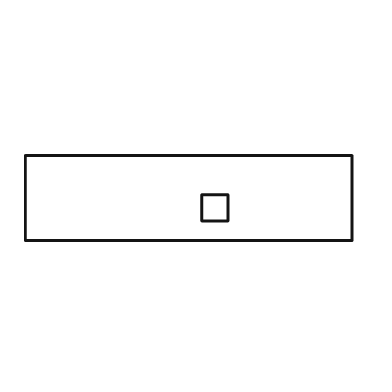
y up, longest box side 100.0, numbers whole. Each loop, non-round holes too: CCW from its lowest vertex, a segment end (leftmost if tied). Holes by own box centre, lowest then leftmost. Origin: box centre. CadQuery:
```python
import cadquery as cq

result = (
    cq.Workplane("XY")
    .moveTo(-50.0, -13.0)
    .lineTo(50.0, -13.0)
    .lineTo(50.0, 13.0)
    .lineTo(-50.0, 13.0)
    .close()
    .moveTo(4.0, -7.0)
    .lineTo(12.0, -7.0)
    .lineTo(12.0, 1.0)
    .lineTo(4.0, 1.0)
    .close()
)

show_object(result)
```